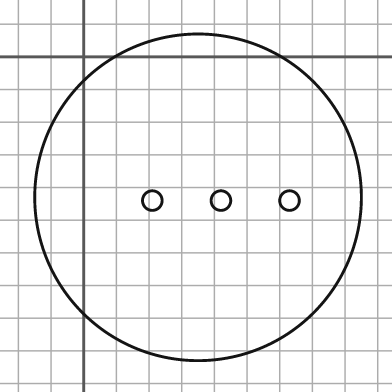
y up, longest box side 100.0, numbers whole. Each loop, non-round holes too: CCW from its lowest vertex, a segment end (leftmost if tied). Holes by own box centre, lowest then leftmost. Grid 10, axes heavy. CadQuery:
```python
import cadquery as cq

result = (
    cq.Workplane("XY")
    .moveTo(35.0, -43.0)
    .circle(50.0)
    .moveTo(21.0, -44.0)
    .circle(3.0)
    .moveTo(42.0, -44.0)
    .circle(3.0)
    .moveTo(63.0, -44.0)
    .circle(3.0)
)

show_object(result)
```